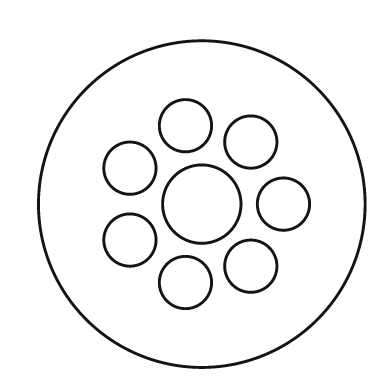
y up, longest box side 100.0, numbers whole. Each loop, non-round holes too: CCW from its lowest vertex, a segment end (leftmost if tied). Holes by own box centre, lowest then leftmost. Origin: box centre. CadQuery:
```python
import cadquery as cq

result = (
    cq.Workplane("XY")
    .moveTo(0.0, 0.0)
    .circle(50.0)
    .moveTo(-5.0, -24.0)
    .circle(8.0)
    .moveTo(15.0, -19.0)
    .circle(8.0)
    .moveTo(-22.0, -11.0)
    .circle(8.0)
    .moveTo(0.0, 0.0)
    .circle(12.0)
    .moveTo(25.0, 0.0)
    .circle(8.0)
    .moveTo(-22.0, 11.0)
    .circle(8.0)
    .moveTo(15.0, 19.0)
    .circle(8.0)
    .moveTo(-5.0, 24.0)
    .circle(8.0)
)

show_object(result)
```